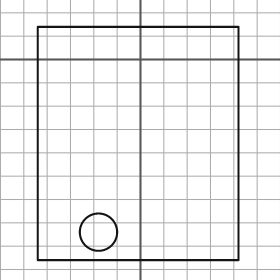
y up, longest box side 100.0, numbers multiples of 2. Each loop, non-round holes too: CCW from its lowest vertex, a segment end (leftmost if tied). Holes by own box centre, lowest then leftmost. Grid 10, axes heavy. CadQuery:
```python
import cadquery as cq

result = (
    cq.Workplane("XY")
    .moveTo(-44.0, -86.0)
    .lineTo(42.0, -86.0)
    .lineTo(42.0, 14.0)
    .lineTo(-44.0, 14.0)
    .close()
    .moveTo(-18.0, -74.0)
    .circle(8.0)
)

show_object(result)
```